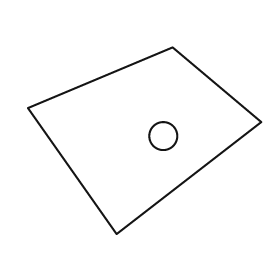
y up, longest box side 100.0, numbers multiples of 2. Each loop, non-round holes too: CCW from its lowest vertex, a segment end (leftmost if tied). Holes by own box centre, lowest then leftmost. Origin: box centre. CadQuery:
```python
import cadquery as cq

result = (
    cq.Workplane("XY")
    .moveTo(-12.0, -40.0)
    .lineTo(50.0, 8.0)
    .lineTo(12.0, 40.0)
    .lineTo(-50.0, 14.0)
    .close()
    .moveTo(8.0, 2.0)
    .circle(6.0)
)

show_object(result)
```